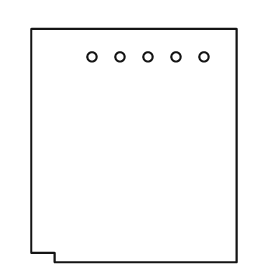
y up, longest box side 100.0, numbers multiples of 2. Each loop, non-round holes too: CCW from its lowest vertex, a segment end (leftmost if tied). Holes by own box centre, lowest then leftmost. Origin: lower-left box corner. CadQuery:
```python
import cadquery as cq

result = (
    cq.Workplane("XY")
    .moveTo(10.0, 0.0)
    .lineTo(88.0, 0.0)
    .lineTo(88.0, 100.0)
    .lineTo(0.0, 100.0)
    .lineTo(0.0, 4.0)
    .lineTo(10.0, 4.0)
    .close()
    .moveTo(26.0, 88.0)
    .circle(2.0)
    .moveTo(38.0, 88.0)
    .circle(2.0)
    .moveTo(50.0, 88.0)
    .circle(2.0)
    .moveTo(62.0, 88.0)
    .circle(2.0)
    .moveTo(74.0, 88.0)
    .circle(2.0)
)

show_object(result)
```